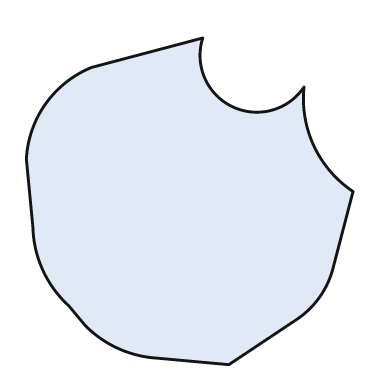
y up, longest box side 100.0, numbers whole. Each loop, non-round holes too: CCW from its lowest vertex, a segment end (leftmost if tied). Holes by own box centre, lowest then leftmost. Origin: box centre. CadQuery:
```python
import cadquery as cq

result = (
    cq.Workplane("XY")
    .moveTo(12.0, -50.0)
    .lineTo(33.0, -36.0)
    .threePointArc((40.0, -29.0), (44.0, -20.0))
    .lineTo(50.0, 3.0)
    .threePointArc((38.0, 17.0), (35.0, 35.0))
    .threePointArc((13.0, 29.0), (4.0, 50.0))
    .lineTo(-30.0, 41.0)
    .threePointArc((-44.0, 30.0), (-50.0, 13.0))
    .lineTo(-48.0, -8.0)
    .threePointArc((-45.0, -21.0), (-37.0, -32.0))
    .lineTo(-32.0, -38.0)
    .threePointArc((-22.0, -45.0), (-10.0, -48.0))
    .close()
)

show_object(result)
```